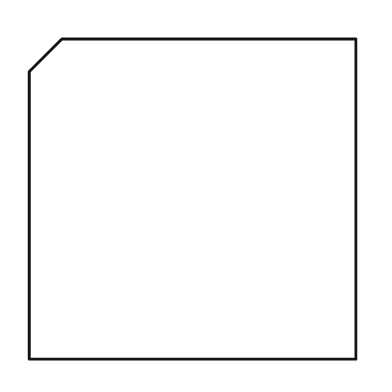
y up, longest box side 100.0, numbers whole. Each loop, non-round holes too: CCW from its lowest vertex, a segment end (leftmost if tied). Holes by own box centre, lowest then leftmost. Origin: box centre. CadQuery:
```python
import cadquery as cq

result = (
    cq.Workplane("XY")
    .moveTo(-50.0, -49.0)
    .lineTo(50.0, -49.0)
    .lineTo(50.0, 49.0)
    .lineTo(-40.0, 49.0)
    .lineTo(-50.0, 39.0)
    .close()
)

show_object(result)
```